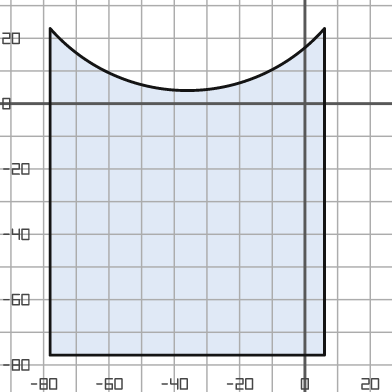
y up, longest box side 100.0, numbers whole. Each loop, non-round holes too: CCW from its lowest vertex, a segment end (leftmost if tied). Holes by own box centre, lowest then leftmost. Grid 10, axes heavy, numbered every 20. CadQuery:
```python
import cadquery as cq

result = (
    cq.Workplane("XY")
    .moveTo(-78.0, -77.0)
    .lineTo(6.0, -77.0)
    .lineTo(6.0, 23.0)
    .threePointArc((-36.0, 4.0), (-78.0, 23.0))
    .close()
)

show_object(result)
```